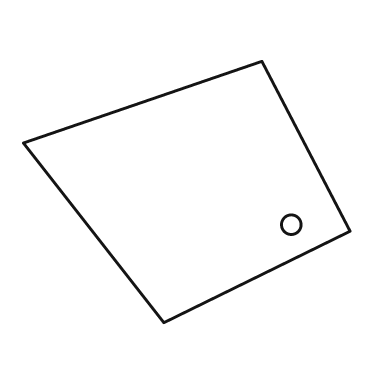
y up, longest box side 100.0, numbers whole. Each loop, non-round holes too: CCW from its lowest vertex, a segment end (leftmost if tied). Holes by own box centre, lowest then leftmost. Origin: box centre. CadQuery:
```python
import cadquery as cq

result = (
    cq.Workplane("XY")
    .moveTo(-7.0, -40.0)
    .lineTo(50.0, -12.0)
    .lineTo(23.0, 40.0)
    .lineTo(-50.0, 15.0)
    .close()
    .moveTo(32.0, -10.0)
    .circle(3.0)
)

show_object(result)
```